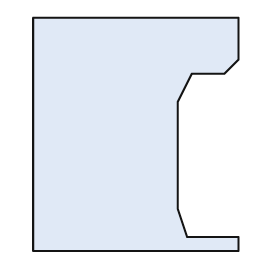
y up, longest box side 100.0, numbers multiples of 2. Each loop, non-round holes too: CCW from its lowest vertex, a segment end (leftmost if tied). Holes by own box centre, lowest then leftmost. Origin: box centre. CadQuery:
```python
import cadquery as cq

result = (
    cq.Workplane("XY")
    .moveTo(-44.0, -50.0)
    .lineTo(44.0, -50.0)
    .lineTo(44.0, -44.0)
    .lineTo(22.0, -44.0)
    .lineTo(18.0, -32.0)
    .lineTo(18.0, 14.0)
    .lineTo(24.0, 26.0)
    .lineTo(38.0, 26.0)
    .lineTo(44.0, 32.0)
    .lineTo(44.0, 50.0)
    .lineTo(-44.0, 50.0)
    .close()
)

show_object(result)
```